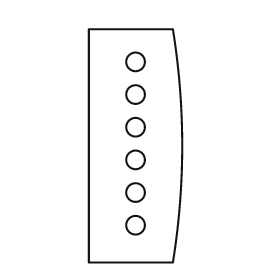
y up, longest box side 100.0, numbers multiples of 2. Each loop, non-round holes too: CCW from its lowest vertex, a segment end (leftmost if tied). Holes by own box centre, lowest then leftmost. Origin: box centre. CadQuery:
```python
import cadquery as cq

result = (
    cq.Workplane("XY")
    .moveTo(-20.0, -50.0)
    .lineTo(16.0, -50.0)
    .threePointArc((20.0, 0.0), (16.0, 50.0))
    .lineTo(-20.0, 50.0)
    .close()
    .moveTo(0.0, -34.0)
    .circle(4.0)
    .moveTo(0.0, -20.0)
    .circle(4.0)
    .moveTo(0.0, -6.0)
    .circle(4.0)
    .moveTo(0.0, 8.0)
    .circle(4.0)
    .moveTo(0.0, 22.0)
    .circle(4.0)
    .moveTo(0.0, 36.0)
    .circle(4.0)
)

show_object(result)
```